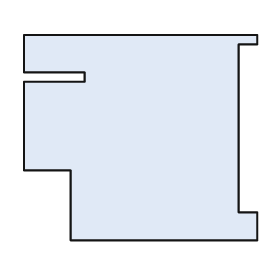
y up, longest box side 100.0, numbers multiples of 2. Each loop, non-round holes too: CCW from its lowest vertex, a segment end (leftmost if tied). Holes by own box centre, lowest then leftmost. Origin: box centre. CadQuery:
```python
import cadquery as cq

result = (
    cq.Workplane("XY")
    .moveTo(-30.0, -44.0)
    .lineTo(50.0, -44.0)
    .lineTo(50.0, -32.0)
    .lineTo(42.0, -32.0)
    .lineTo(42.0, 40.0)
    .lineTo(50.0, 40.0)
    .lineTo(50.0, 44.0)
    .lineTo(-50.0, 44.0)
    .lineTo(-50.0, 28.0)
    .lineTo(-24.0, 28.0)
    .lineTo(-24.0, 24.0)
    .lineTo(-50.0, 24.0)
    .lineTo(-50.0, -14.0)
    .lineTo(-30.0, -14.0)
    .close()
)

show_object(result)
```